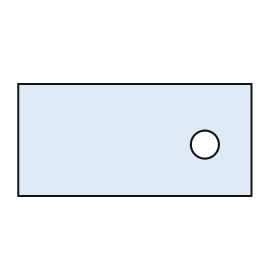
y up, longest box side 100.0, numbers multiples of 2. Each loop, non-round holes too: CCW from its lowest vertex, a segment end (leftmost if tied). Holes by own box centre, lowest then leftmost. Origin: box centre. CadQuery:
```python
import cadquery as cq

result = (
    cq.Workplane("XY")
    .moveTo(-50.0, -24.0)
    .lineTo(50.0, -24.0)
    .lineTo(50.0, 24.0)
    .lineTo(-50.0, 24.0)
    .close()
    .moveTo(30.0, -2.0)
    .circle(6.0)
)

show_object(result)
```